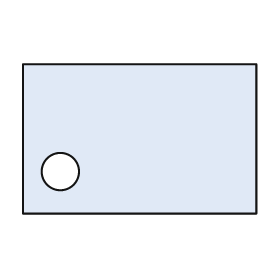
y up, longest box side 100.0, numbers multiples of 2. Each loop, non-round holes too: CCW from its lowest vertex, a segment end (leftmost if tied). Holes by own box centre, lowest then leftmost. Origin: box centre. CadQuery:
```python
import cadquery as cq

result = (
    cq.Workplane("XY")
    .moveTo(-50.0, -32.0)
    .lineTo(50.0, -32.0)
    .lineTo(50.0, 32.0)
    .lineTo(-50.0, 32.0)
    .close()
    .moveTo(-34.0, -14.0)
    .circle(8.0)
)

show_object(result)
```